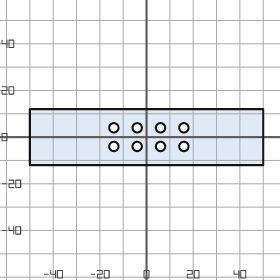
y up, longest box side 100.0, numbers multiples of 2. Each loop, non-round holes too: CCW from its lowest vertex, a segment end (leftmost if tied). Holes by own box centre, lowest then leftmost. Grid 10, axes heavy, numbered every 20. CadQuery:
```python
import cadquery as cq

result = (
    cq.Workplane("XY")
    .moveTo(-50.0, -12.0)
    .lineTo(50.0, -12.0)
    .lineTo(50.0, 12.0)
    .lineTo(-50.0, 12.0)
    .close()
    .moveTo(-14.0, -4.0)
    .circle(2.0)
    .moveTo(-4.0, -4.0)
    .circle(2.0)
    .moveTo(6.0, -4.0)
    .circle(2.0)
    .moveTo(16.0, -4.0)
    .circle(2.0)
    .moveTo(-14.0, 4.0)
    .circle(2.0)
    .moveTo(-4.0, 4.0)
    .circle(2.0)
    .moveTo(6.0, 4.0)
    .circle(2.0)
    .moveTo(16.0, 4.0)
    .circle(2.0)
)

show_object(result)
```